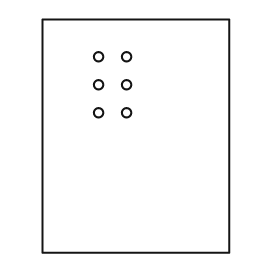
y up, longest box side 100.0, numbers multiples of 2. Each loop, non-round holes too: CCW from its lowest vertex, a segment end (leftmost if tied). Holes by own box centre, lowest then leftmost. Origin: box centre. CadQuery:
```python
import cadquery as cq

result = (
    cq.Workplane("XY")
    .moveTo(-40.0, -50.0)
    .lineTo(40.0, -50.0)
    .lineTo(40.0, 50.0)
    .lineTo(-40.0, 50.0)
    .close()
    .moveTo(-16.0, 10.0)
    .circle(2.0)
    .moveTo(-4.0, 10.0)
    .circle(2.0)
    .moveTo(-16.0, 22.0)
    .circle(2.0)
    .moveTo(-4.0, 22.0)
    .circle(2.0)
    .moveTo(-16.0, 34.0)
    .circle(2.0)
    .moveTo(-4.0, 34.0)
    .circle(2.0)
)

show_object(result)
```